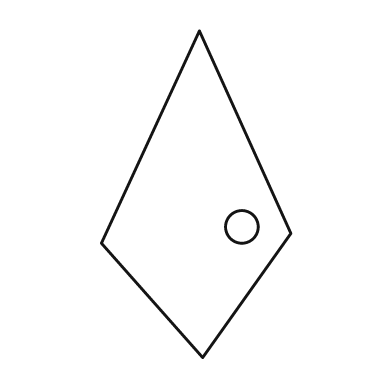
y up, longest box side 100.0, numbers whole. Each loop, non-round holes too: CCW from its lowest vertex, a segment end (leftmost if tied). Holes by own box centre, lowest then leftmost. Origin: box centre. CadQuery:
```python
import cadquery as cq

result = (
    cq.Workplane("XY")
    .moveTo(2.0, -50.0)
    .lineTo(29.0, -12.0)
    .lineTo(1.0, 50.0)
    .lineTo(-29.0, -15.0)
    .close()
    .moveTo(14.0, -10.0)
    .circle(5.0)
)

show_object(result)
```